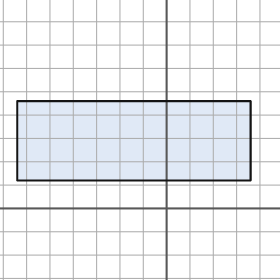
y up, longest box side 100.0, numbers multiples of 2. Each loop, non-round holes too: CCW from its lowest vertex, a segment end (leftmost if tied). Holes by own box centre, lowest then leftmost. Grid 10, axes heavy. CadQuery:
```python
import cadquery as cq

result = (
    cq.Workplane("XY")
    .moveTo(-64.0, 12.0)
    .lineTo(36.0, 12.0)
    .lineTo(36.0, 46.0)
    .lineTo(-64.0, 46.0)
    .close()
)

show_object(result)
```